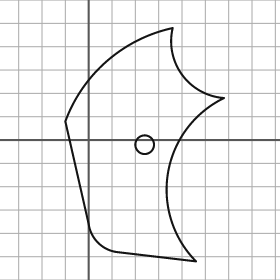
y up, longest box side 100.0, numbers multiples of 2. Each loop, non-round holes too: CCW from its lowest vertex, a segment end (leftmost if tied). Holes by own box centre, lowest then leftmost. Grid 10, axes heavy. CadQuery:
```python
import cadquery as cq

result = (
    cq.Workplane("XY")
    .moveTo(46.0, -52.0)
    .threePointArc((34.0, -14.0), (58.0, 18.0))
    .threePointArc((40.0, 28.0), (36.0, 48.0))
    .threePointArc((8.0, 34.0), (-10.0, 8.0))
    .lineTo(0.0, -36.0)
    .threePointArc((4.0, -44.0), (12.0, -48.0))
    .close()
    .moveTo(24.0, -2.0)
    .circle(4.0)
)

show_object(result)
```